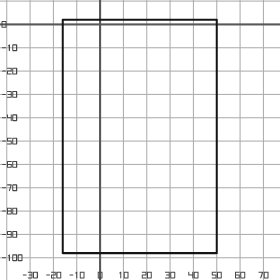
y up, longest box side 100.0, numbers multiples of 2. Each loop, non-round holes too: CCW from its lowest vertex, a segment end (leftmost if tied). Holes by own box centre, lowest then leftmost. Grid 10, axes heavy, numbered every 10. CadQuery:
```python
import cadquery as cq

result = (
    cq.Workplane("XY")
    .moveTo(-16.0, -98.0)
    .lineTo(50.0, -98.0)
    .lineTo(50.0, 2.0)
    .lineTo(-16.0, 2.0)
    .close()
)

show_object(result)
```